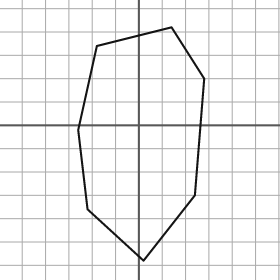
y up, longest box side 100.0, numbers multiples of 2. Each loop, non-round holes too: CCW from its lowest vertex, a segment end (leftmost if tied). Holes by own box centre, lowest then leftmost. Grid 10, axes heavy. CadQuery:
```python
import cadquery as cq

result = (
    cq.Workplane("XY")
    .moveTo(2.0, -58.0)
    .lineTo(24.0, -30.0)
    .lineTo(28.0, 20.0)
    .lineTo(14.0, 42.0)
    .lineTo(-18.0, 34.0)
    .lineTo(-26.0, -2.0)
    .lineTo(-22.0, -36.0)
    .close()
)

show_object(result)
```